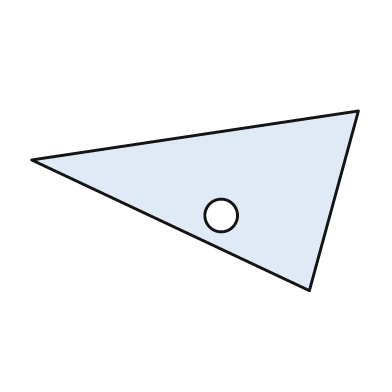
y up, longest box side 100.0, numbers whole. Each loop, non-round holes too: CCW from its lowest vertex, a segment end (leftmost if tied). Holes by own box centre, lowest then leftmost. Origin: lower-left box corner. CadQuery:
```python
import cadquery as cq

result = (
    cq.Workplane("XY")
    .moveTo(85.0, 0.0)
    .lineTo(100.0, 55.0)
    .lineTo(0.0, 40.0)
    .close()
    .moveTo(58.0, 23.0)
    .circle(5.0)
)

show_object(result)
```